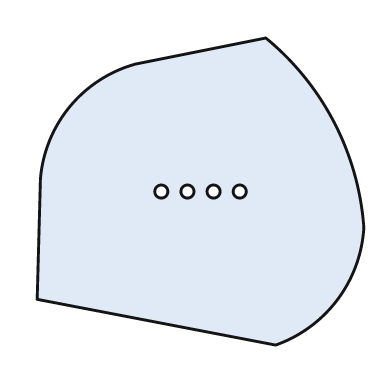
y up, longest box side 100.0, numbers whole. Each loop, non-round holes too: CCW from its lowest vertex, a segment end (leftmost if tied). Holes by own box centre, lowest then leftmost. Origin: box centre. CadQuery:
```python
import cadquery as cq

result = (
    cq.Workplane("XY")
    .moveTo(23.0, -47.0)
    .threePointArc((42.0, -33.0), (50.0, -11.0))
    .threePointArc((41.0, 21.0), (20.0, 47.0))
    .lineTo(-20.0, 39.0)
    .threePointArc((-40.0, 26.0), (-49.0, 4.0))
    .lineTo(-50.0, -33.0)
    .close()
    .moveTo(-12.0, 0.0)
    .circle(2.0)
    .moveTo(-4.0, 0.0)
    .circle(2.0)
    .moveTo(4.0, 0.0)
    .circle(2.0)
    .moveTo(12.0, 0.0)
    .circle(2.0)
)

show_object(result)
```